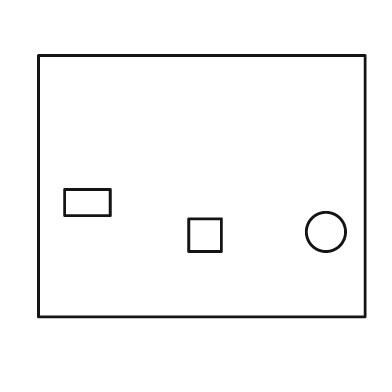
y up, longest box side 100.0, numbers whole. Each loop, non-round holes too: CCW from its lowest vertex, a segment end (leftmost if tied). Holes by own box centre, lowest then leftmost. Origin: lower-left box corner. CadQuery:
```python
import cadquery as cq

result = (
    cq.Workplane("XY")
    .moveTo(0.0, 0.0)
    .lineTo(100.0, 0.0)
    .lineTo(100.0, 80.0)
    .lineTo(0.0, 80.0)
    .close()
    .moveTo(46.0, 20.0)
    .lineTo(56.0, 20.0)
    .lineTo(56.0, 30.0)
    .lineTo(46.0, 30.0)
    .close()
    .moveTo(88.0, 26.0)
    .circle(6.0)
    .moveTo(8.0, 31.0)
    .lineTo(22.0, 31.0)
    .lineTo(22.0, 39.0)
    .lineTo(8.0, 39.0)
    .close()
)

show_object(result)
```